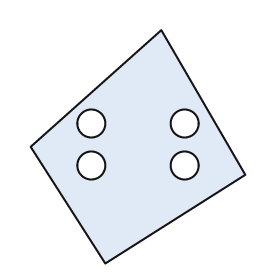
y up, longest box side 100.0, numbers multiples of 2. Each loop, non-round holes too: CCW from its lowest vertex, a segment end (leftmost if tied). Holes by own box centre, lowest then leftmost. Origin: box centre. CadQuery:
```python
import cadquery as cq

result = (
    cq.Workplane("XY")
    .moveTo(-14.0, -50.0)
    .lineTo(46.0, -12.0)
    .lineTo(10.0, 50.0)
    .lineTo(-46.0, 0.0)
    .close()
    .moveTo(-20.0, -8.0)
    .circle(6.0)
    .moveTo(20.0, -8.0)
    .circle(6.0)
    .moveTo(-20.0, 10.0)
    .circle(6.0)
    .moveTo(20.0, 10.0)
    .circle(6.0)
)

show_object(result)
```